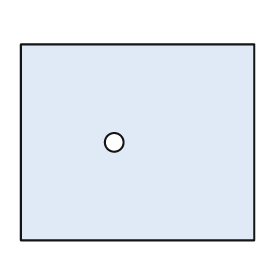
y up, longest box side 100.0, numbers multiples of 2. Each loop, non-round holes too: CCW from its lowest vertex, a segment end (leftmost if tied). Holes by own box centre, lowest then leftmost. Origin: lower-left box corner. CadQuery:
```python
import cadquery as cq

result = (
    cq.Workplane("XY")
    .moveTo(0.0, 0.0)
    .lineTo(100.0, 0.0)
    .lineTo(100.0, 84.0)
    .lineTo(0.0, 84.0)
    .close()
    .moveTo(40.0, 42.0)
    .circle(4.0)
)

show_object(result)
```